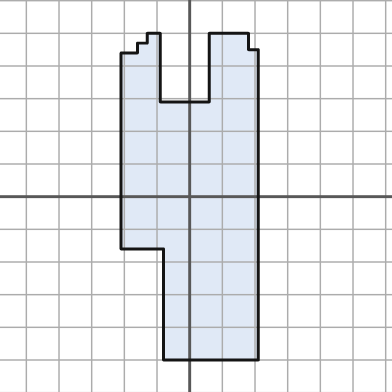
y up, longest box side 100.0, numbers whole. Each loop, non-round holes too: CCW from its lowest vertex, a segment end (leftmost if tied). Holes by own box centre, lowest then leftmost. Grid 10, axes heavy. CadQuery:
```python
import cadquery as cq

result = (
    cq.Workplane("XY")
    .moveTo(-8.0, -50.0)
    .lineTo(21.0, -50.0)
    .lineTo(21.0, 45.0)
    .lineTo(18.0, 45.0)
    .lineTo(18.0, 50.0)
    .lineTo(6.0, 50.0)
    .lineTo(6.0, 29.0)
    .lineTo(-9.0, 29.0)
    .lineTo(-9.0, 50.0)
    .lineTo(-13.0, 50.0)
    .lineTo(-13.0, 47.0)
    .lineTo(-16.0, 47.0)
    .lineTo(-16.0, 44.0)
    .lineTo(-21.0, 44.0)
    .lineTo(-21.0, -16.0)
    .lineTo(-8.0, -16.0)
    .close()
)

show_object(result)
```